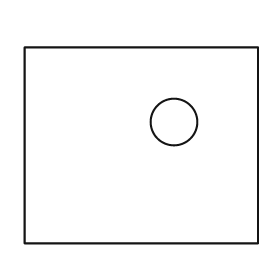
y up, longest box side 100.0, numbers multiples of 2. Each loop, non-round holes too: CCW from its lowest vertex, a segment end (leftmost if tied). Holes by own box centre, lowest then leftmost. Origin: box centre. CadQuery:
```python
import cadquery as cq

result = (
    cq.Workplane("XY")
    .moveTo(-50.0, -42.0)
    .lineTo(50.0, -42.0)
    .lineTo(50.0, 42.0)
    .lineTo(-50.0, 42.0)
    .close()
    .moveTo(14.0, 10.0)
    .circle(10.0)
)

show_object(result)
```